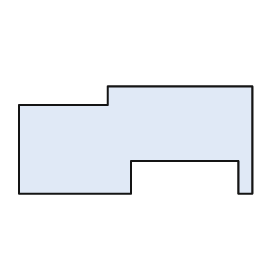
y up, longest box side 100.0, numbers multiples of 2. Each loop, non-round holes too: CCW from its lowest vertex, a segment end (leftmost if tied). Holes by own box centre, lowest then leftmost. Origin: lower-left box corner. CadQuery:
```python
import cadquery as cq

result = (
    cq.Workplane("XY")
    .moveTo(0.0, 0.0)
    .lineTo(48.0, 0.0)
    .lineTo(48.0, 14.0)
    .lineTo(94.0, 14.0)
    .lineTo(94.0, 0.0)
    .lineTo(100.0, 0.0)
    .lineTo(100.0, 46.0)
    .lineTo(38.0, 46.0)
    .lineTo(38.0, 38.0)
    .lineTo(0.0, 38.0)
    .close()
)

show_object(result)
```